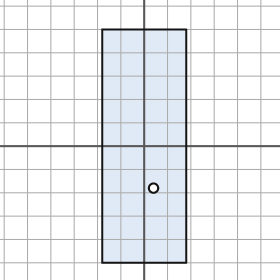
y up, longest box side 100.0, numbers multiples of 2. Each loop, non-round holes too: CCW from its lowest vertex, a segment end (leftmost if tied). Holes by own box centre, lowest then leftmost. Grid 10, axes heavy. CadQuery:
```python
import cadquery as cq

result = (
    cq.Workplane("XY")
    .moveTo(-18.0, -50.0)
    .lineTo(18.0, -50.0)
    .lineTo(18.0, 50.0)
    .lineTo(-18.0, 50.0)
    .close()
    .moveTo(4.0, -18.0)
    .circle(2.0)
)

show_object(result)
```